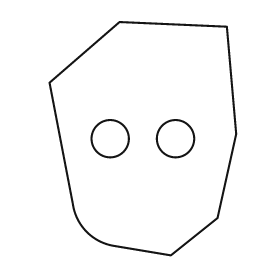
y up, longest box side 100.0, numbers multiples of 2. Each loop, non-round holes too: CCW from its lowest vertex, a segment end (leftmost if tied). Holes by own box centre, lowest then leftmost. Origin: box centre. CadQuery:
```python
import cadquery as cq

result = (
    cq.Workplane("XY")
    .moveTo(12.0, -50.0)
    .lineTo(32.0, -34.0)
    .lineTo(40.0, 2.0)
    .lineTo(36.0, 48.0)
    .lineTo(-10.0, 50.0)
    .lineTo(-40.0, 24.0)
    .lineTo(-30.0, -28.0)
    .threePointArc((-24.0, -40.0), (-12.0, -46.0))
    .close()
    .moveTo(-14.0, 0.0)
    .circle(8.0)
    .moveTo(14.0, 0.0)
    .circle(8.0)
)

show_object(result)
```